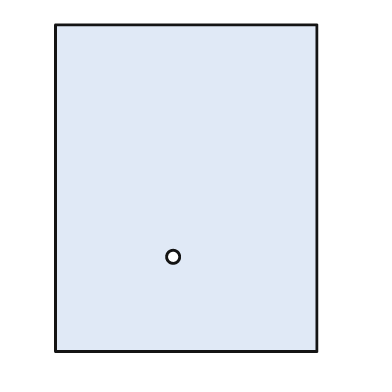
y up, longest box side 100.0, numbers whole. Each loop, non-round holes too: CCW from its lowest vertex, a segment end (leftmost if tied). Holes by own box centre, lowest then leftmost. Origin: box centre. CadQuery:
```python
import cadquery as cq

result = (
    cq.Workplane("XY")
    .moveTo(-40.0, -50.0)
    .lineTo(40.0, -50.0)
    .lineTo(40.0, 50.0)
    .lineTo(-40.0, 50.0)
    .close()
    .moveTo(-4.0, -21.0)
    .circle(2.0)
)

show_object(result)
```